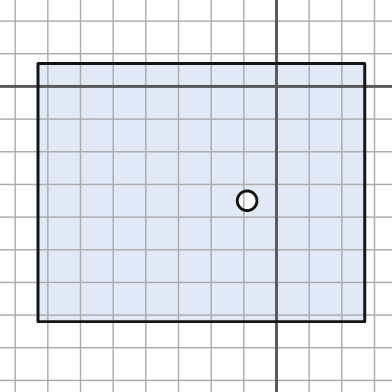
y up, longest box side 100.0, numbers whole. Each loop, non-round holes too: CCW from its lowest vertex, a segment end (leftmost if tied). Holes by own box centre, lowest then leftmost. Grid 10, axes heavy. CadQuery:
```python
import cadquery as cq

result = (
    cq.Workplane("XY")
    .moveTo(-73.0, -72.0)
    .lineTo(27.0, -72.0)
    .lineTo(27.0, 7.0)
    .lineTo(-73.0, 7.0)
    .close()
    .moveTo(-9.0, -35.0)
    .circle(3.0)
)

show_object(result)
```